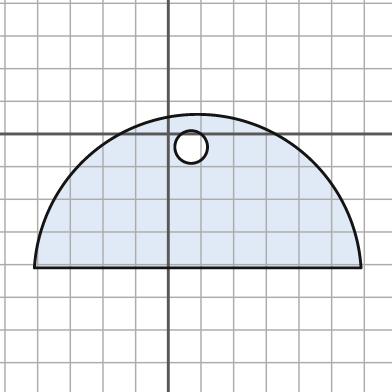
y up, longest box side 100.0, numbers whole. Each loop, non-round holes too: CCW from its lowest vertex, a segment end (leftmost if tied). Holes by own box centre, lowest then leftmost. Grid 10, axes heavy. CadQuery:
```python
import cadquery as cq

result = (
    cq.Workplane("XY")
    .moveTo(-41.0, -41.0)
    .lineTo(59.0, -41.0)
    .threePointArc((9.0, 6.0), (-41.0, -41.0))
    .close()
    .moveTo(7.0, -4.0)
    .circle(5.0)
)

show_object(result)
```